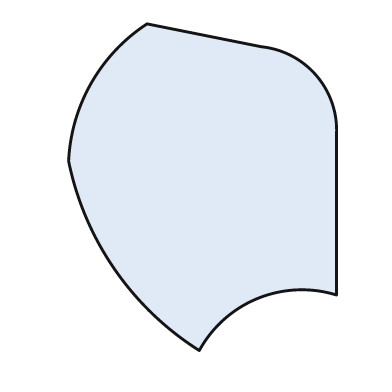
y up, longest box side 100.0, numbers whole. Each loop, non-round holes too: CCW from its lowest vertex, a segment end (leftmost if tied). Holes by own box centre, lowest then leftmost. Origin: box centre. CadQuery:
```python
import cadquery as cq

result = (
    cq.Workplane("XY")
    .moveTo(-1.0, -50.0)
    .threePointArc((17.0, -34.0), (41.0, -33.0))
    .lineTo(41.0, 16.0)
    .threePointArc((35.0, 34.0), (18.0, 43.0))
    .lineTo(-17.0, 50.0)
    .threePointArc((-34.0, 32.0), (-41.0, 8.0))
    .threePointArc((-27.0, -25.0), (-1.0, -50.0))
    .close()
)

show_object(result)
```